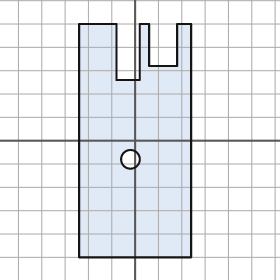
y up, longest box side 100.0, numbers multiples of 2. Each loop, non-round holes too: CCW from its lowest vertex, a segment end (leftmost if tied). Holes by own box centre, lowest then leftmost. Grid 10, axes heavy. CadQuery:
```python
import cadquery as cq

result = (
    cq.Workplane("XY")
    .moveTo(-24.0, -50.0)
    .lineTo(24.0, -50.0)
    .lineTo(24.0, 50.0)
    .lineTo(18.0, 50.0)
    .lineTo(18.0, 32.0)
    .lineTo(6.0, 32.0)
    .lineTo(6.0, 50.0)
    .lineTo(2.0, 50.0)
    .lineTo(2.0, 26.0)
    .lineTo(-8.0, 26.0)
    .lineTo(-8.0, 50.0)
    .lineTo(-24.0, 50.0)
    .close()
    .moveTo(-2.0, -8.0)
    .circle(4.0)
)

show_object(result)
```